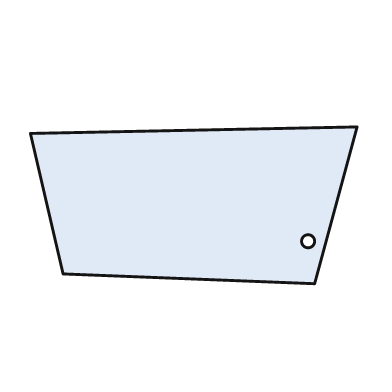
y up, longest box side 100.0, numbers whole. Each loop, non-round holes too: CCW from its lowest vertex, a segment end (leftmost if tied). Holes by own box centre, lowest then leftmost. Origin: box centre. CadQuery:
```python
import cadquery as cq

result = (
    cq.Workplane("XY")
    .moveTo(37.0, -24.0)
    .lineTo(50.0, 24.0)
    .lineTo(-50.0, 22.0)
    .lineTo(-40.0, -21.0)
    .close()
    .moveTo(35.0, -11.0)
    .circle(2.0)
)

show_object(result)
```